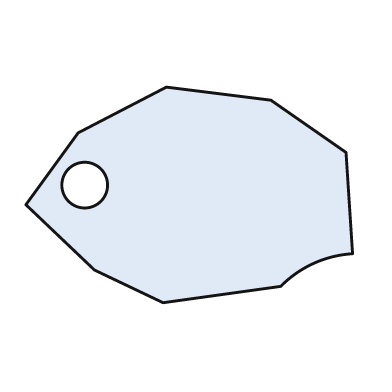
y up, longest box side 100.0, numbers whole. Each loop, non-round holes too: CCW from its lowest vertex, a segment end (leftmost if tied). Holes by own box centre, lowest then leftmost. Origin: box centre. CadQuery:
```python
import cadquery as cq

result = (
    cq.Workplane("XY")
    .moveTo(-8.0, -33.0)
    .lineTo(28.0, -28.0)
    .threePointArc((38.0, -21.0), (50.0, -18.0))
    .lineTo(48.0, 13.0)
    .lineTo(25.0, 29.0)
    .lineTo(-7.0, 33.0)
    .lineTo(-34.0, 19.0)
    .lineTo(-50.0, -3.0)
    .lineTo(-29.0, -23.0)
    .close()
    .moveTo(-32.0, 3.0)
    .circle(7.0)
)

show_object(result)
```